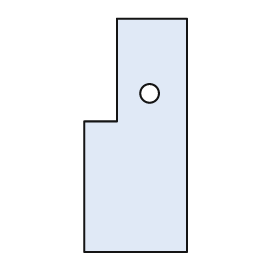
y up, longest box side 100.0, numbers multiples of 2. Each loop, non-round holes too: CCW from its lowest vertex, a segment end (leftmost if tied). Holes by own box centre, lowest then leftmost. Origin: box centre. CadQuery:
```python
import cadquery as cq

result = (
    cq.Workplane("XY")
    .moveTo(-22.0, -50.0)
    .lineTo(22.0, -50.0)
    .lineTo(22.0, 50.0)
    .lineTo(-8.0, 50.0)
    .lineTo(-8.0, 6.0)
    .lineTo(-22.0, 6.0)
    .close()
    .moveTo(6.0, 18.0)
    .circle(4.0)
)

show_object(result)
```